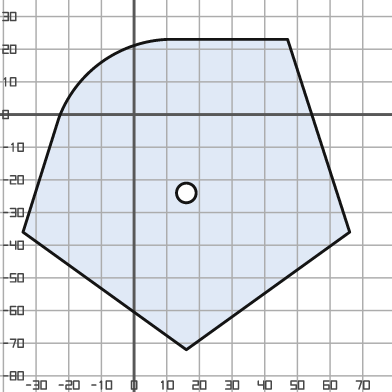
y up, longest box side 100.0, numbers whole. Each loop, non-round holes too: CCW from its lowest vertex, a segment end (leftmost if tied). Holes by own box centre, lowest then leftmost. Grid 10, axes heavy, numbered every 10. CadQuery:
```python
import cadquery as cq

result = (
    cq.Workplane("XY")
    .moveTo(16.0, -72.0)
    .lineTo(66.0, -36.0)
    .lineTo(47.0, 23.0)
    .lineTo(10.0, 23.0)
    .threePointArc((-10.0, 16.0), (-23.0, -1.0))
    .lineTo(-34.0, -36.0)
    .close()
    .moveTo(16.0, -24.0)
    .circle(3.0)
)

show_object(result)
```